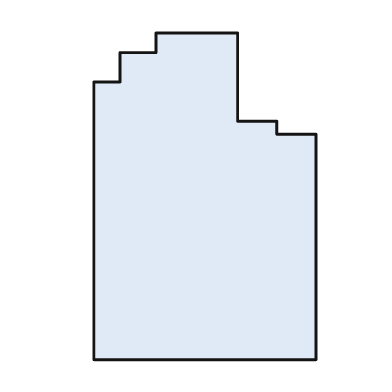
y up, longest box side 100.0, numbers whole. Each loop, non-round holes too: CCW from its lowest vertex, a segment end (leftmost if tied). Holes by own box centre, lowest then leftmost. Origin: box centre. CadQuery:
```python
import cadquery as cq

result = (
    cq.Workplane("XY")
    .moveTo(-34.0, -50.0)
    .lineTo(34.0, -50.0)
    .lineTo(34.0, 19.0)
    .lineTo(22.0, 19.0)
    .lineTo(22.0, 23.0)
    .lineTo(10.0, 23.0)
    .lineTo(10.0, 50.0)
    .lineTo(-15.0, 50.0)
    .lineTo(-15.0, 44.0)
    .lineTo(-26.0, 44.0)
    .lineTo(-26.0, 35.0)
    .lineTo(-34.0, 35.0)
    .close()
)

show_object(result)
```